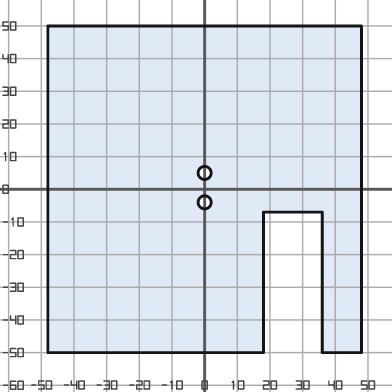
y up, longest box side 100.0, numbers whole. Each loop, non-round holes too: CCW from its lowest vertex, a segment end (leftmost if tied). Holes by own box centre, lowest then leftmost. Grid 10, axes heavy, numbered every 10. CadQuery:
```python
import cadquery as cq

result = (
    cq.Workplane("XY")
    .moveTo(-48.0, -50.0)
    .lineTo(18.0, -50.0)
    .lineTo(18.0, -7.0)
    .lineTo(36.0, -7.0)
    .lineTo(36.0, -50.0)
    .lineTo(48.0, -50.0)
    .lineTo(48.0, 50.0)
    .lineTo(-48.0, 50.0)
    .close()
    .moveTo(0.0, -4.0)
    .circle(2.0)
    .moveTo(0.0, 5.0)
    .circle(2.0)
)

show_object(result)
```